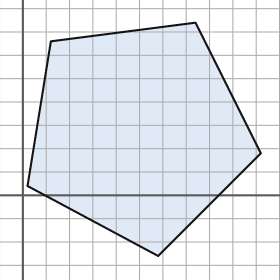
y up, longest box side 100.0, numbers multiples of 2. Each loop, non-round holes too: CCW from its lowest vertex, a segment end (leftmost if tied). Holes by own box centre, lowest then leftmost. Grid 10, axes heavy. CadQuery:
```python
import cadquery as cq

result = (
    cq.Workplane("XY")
    .moveTo(58.0, -26.0)
    .lineTo(102.0, 18.0)
    .lineTo(74.0, 74.0)
    .lineTo(12.0, 66.0)
    .lineTo(2.0, 4.0)
    .close()
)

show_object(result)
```